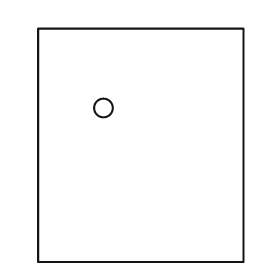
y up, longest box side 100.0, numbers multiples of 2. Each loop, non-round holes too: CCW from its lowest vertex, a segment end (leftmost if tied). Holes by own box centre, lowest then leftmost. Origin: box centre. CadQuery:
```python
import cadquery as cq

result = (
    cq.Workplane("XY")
    .moveTo(-44.0, -50.0)
    .lineTo(44.0, -50.0)
    .lineTo(44.0, 50.0)
    .lineTo(-44.0, 50.0)
    .close()
    .moveTo(-16.0, 16.0)
    .circle(4.0)
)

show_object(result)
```